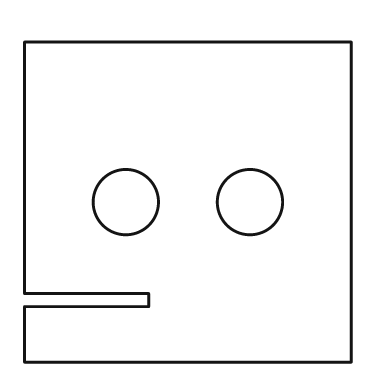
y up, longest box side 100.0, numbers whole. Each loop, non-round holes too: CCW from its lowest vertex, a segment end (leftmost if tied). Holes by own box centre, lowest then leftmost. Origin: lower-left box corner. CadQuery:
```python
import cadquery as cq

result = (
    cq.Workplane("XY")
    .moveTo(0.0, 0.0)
    .lineTo(100.0, 0.0)
    .lineTo(100.0, 98.0)
    .lineTo(0.0, 98.0)
    .lineTo(0.0, 21.0)
    .lineTo(38.0, 21.0)
    .lineTo(38.0, 17.0)
    .lineTo(0.0, 17.0)
    .close()
    .moveTo(31.0, 49.0)
    .circle(10.0)
    .moveTo(69.0, 49.0)
    .circle(10.0)
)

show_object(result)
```